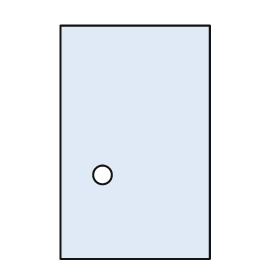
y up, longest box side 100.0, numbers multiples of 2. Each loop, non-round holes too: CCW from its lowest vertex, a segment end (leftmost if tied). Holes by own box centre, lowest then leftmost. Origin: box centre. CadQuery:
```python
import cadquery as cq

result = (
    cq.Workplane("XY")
    .moveTo(-32.0, -50.0)
    .lineTo(32.0, -50.0)
    .lineTo(32.0, 50.0)
    .lineTo(-32.0, 50.0)
    .close()
    .moveTo(-14.0, -14.0)
    .circle(4.0)
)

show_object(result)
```